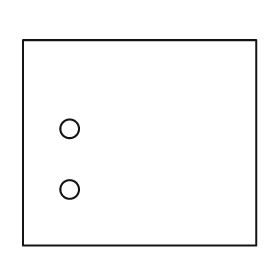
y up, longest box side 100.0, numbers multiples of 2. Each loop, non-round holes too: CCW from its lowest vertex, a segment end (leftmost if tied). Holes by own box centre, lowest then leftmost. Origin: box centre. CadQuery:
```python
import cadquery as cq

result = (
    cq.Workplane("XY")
    .moveTo(-50.0, -44.0)
    .lineTo(50.0, -44.0)
    .lineTo(50.0, 44.0)
    .lineTo(-50.0, 44.0)
    .close()
    .moveTo(-30.0, -20.0)
    .circle(4.0)
    .moveTo(-30.0, 6.0)
    .circle(4.0)
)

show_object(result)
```